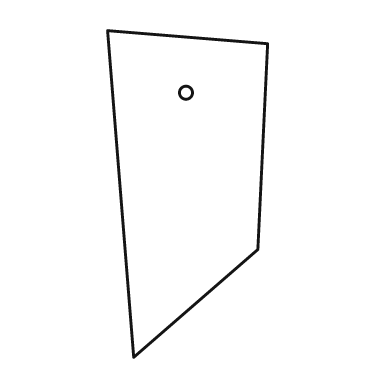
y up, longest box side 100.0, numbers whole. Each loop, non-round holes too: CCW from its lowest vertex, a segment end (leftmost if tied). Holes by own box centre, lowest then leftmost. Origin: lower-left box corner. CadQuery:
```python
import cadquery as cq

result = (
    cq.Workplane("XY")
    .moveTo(8.0, 0.0)
    .lineTo(46.0, 33.0)
    .lineTo(49.0, 96.0)
    .lineTo(0.0, 100.0)
    .close()
    .moveTo(24.0, 81.0)
    .circle(2.0)
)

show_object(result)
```